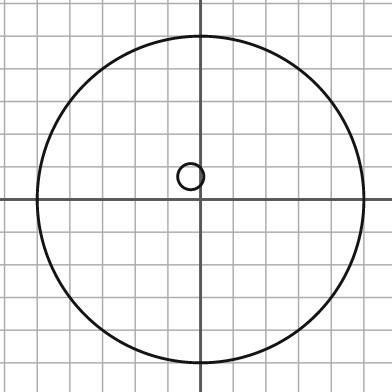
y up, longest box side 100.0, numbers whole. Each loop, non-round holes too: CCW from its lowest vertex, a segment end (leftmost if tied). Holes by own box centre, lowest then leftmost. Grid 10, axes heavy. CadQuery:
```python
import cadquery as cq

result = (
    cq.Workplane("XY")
    .moveTo(0.0, 0.0)
    .circle(50.0)
    .moveTo(-3.0, 7.0)
    .circle(4.0)
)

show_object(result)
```